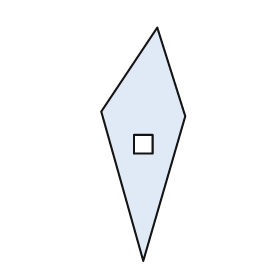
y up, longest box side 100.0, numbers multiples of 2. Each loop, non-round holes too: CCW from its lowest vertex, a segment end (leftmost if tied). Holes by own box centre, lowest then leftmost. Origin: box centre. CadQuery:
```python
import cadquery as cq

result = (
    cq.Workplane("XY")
    .moveTo(0.0, -50.0)
    .lineTo(18.0, 12.0)
    .lineTo(6.0, 50.0)
    .lineTo(-18.0, 14.0)
    .close()
    .moveTo(-4.0, -4.0)
    .lineTo(4.0, -4.0)
    .lineTo(4.0, 4.0)
    .lineTo(-4.0, 4.0)
    .close()
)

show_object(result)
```